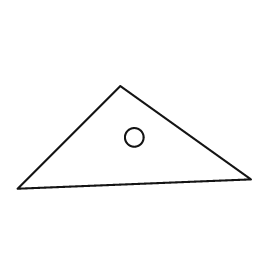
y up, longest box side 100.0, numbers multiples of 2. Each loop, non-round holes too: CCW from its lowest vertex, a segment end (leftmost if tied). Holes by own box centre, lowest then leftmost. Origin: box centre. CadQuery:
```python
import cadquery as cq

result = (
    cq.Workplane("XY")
    .moveTo(-50.0, -22.0)
    .lineTo(50.0, -18.0)
    .lineTo(-6.0, 22.0)
    .close()
    .moveTo(0.0, 0.0)
    .circle(4.0)
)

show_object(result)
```